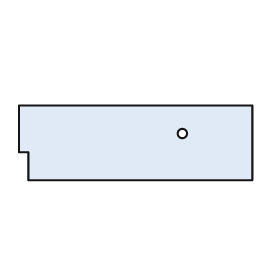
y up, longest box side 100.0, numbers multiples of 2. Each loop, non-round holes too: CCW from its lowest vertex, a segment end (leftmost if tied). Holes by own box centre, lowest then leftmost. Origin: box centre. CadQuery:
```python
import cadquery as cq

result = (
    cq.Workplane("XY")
    .moveTo(-46.0, -16.0)
    .lineTo(50.0, -16.0)
    .lineTo(50.0, 16.0)
    .lineTo(-50.0, 16.0)
    .lineTo(-50.0, -4.0)
    .lineTo(-46.0, -4.0)
    .close()
    .moveTo(20.0, 4.0)
    .circle(2.0)
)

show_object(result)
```